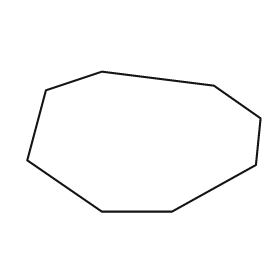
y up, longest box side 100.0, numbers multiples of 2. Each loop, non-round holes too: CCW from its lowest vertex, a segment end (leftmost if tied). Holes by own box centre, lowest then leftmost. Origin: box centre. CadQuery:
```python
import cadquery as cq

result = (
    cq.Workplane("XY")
    .moveTo(-18.0, -30.0)
    .lineTo(12.0, -30.0)
    .lineTo(48.0, -10.0)
    .lineTo(50.0, 10.0)
    .lineTo(30.0, 24.0)
    .lineTo(-18.0, 30.0)
    .lineTo(-42.0, 22.0)
    .lineTo(-50.0, -8.0)
    .close()
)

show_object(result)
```